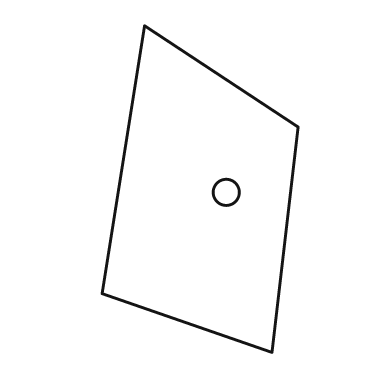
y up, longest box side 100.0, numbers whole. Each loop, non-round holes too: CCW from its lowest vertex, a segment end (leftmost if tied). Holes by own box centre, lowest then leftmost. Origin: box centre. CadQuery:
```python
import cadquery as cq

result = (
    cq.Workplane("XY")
    .moveTo(22.0, -50.0)
    .lineTo(30.0, 19.0)
    .lineTo(-17.0, 50.0)
    .lineTo(-30.0, -32.0)
    .close()
    .moveTo(8.0, -1.0)
    .circle(4.0)
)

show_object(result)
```